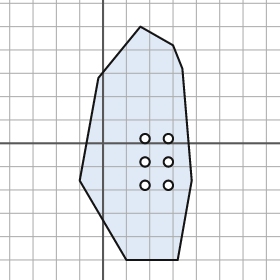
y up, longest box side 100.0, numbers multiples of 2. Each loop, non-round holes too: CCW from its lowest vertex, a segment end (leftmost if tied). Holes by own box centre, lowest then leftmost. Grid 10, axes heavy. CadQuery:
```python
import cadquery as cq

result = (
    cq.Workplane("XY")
    .moveTo(10.0, -50.0)
    .lineTo(32.0, -50.0)
    .lineTo(38.0, -16.0)
    .lineTo(34.0, 32.0)
    .lineTo(30.0, 42.0)
    .lineTo(16.0, 50.0)
    .lineTo(-2.0, 28.0)
    .lineTo(-10.0, -16.0)
    .close()
    .moveTo(18.0, -18.0)
    .circle(2.0)
    .moveTo(28.0, -18.0)
    .circle(2.0)
    .moveTo(18.0, -8.0)
    .circle(2.0)
    .moveTo(28.0, -8.0)
    .circle(2.0)
    .moveTo(18.0, 2.0)
    .circle(2.0)
    .moveTo(28.0, 2.0)
    .circle(2.0)
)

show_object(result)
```